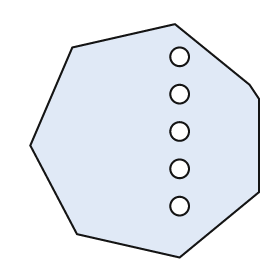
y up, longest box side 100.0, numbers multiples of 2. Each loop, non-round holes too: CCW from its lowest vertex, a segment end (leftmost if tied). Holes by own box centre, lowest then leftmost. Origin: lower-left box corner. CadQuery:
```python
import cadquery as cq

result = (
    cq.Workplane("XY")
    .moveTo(64.0, 0.0)
    .lineTo(98.0, 28.0)
    .lineTo(98.0, 68.0)
    .lineTo(94.0, 74.0)
    .lineTo(62.0, 100.0)
    .lineTo(18.0, 90.0)
    .lineTo(0.0, 48.0)
    .lineTo(20.0, 10.0)
    .close()
    .moveTo(64.0, 22.0)
    .circle(4.0)
    .moveTo(64.0, 38.0)
    .circle(4.0)
    .moveTo(64.0, 54.0)
    .circle(4.0)
    .moveTo(64.0, 70.0)
    .circle(4.0)
    .moveTo(64.0, 86.0)
    .circle(4.0)
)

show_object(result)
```